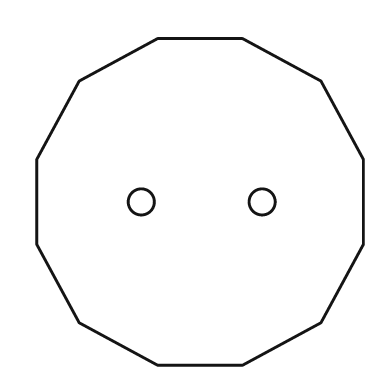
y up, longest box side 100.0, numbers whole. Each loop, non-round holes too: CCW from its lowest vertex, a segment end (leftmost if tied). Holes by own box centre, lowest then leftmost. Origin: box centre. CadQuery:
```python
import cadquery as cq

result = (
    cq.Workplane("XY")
    .moveTo(-13.0, -50.0)
    .lineTo(13.0, -50.0)
    .lineTo(37.0, -37.0)
    .lineTo(50.0, -13.0)
    .lineTo(50.0, 13.0)
    .lineTo(37.0, 37.0)
    .lineTo(13.0, 50.0)
    .lineTo(-13.0, 50.0)
    .lineTo(-37.0, 37.0)
    .lineTo(-50.0, 13.0)
    .lineTo(-50.0, -13.0)
    .lineTo(-37.0, -37.0)
    .close()
    .moveTo(-18.0, 0.0)
    .circle(4.0)
    .moveTo(19.0, 0.0)
    .circle(4.0)
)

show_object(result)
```